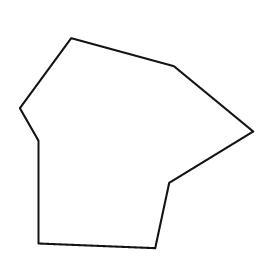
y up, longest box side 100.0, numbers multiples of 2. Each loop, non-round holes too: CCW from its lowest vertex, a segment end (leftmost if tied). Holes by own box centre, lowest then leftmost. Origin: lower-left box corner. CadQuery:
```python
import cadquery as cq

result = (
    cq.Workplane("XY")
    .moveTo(58.0, 0.0)
    .lineTo(64.0, 28.0)
    .lineTo(100.0, 50.0)
    .lineTo(66.0, 78.0)
    .lineTo(22.0, 90.0)
    .lineTo(0.0, 60.0)
    .lineTo(8.0, 46.0)
    .lineTo(8.0, 2.0)
    .close()
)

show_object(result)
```